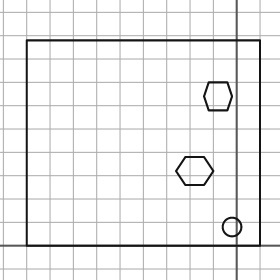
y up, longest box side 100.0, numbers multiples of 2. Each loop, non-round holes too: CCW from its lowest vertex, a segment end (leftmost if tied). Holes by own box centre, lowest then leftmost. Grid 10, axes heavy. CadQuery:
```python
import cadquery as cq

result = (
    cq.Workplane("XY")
    .moveTo(-90.0, 0.0)
    .lineTo(10.0, 0.0)
    .lineTo(10.0, 88.0)
    .lineTo(-90.0, 88.0)
    .close()
    .moveTo(-2.0, 8.0)
    .circle(4.0)
    .moveTo(-22.0, 26.0)
    .lineTo(-14.0, 26.0)
    .lineTo(-10.0, 32.0)
    .lineTo(-14.0, 38.0)
    .lineTo(-22.0, 38.0)
    .lineTo(-26.0, 32.0)
    .close()
    .moveTo(-12.0, 58.0)
    .lineTo(-4.0, 58.0)
    .lineTo(-2.0, 64.0)
    .lineTo(-4.0, 70.0)
    .lineTo(-12.0, 70.0)
    .lineTo(-14.0, 64.0)
    .close()
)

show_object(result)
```